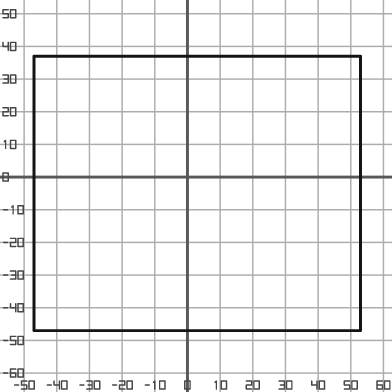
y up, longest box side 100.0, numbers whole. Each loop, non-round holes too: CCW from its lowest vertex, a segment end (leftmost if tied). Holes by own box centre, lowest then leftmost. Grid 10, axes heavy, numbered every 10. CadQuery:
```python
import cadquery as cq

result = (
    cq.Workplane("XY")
    .moveTo(-47.0, -47.0)
    .lineTo(53.0, -47.0)
    .lineTo(53.0, 37.0)
    .lineTo(-47.0, 37.0)
    .close()
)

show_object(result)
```